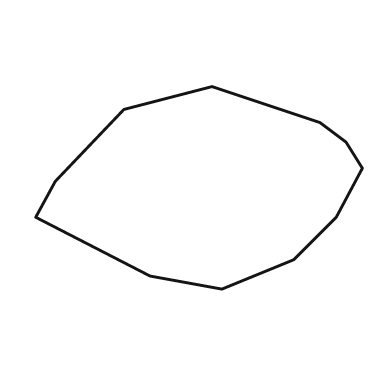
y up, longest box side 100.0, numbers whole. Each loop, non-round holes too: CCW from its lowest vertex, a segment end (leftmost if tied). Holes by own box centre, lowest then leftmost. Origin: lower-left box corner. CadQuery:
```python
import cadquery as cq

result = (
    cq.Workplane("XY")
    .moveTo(57.0, 0.0)
    .lineTo(79.0, 9.0)
    .lineTo(92.0, 22.0)
    .lineTo(100.0, 37.0)
    .lineTo(95.0, 45.0)
    .lineTo(87.0, 51.0)
    .lineTo(54.0, 62.0)
    .lineTo(27.0, 55.0)
    .lineTo(6.0, 33.0)
    .lineTo(0.0, 22.0)
    .lineTo(35.0, 4.0)
    .close()
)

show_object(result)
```